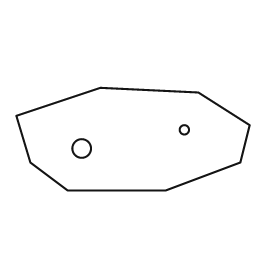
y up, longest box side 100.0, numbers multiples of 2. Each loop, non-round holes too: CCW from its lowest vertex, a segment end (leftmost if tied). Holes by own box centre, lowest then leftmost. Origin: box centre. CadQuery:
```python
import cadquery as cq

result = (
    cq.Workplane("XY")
    .moveTo(-28.0, -22.0)
    .lineTo(14.0, -22.0)
    .lineTo(46.0, -10.0)
    .lineTo(50.0, 6.0)
    .lineTo(28.0, 20.0)
    .lineTo(-14.0, 22.0)
    .lineTo(-50.0, 10.0)
    .lineTo(-44.0, -10.0)
    .close()
    .moveTo(-22.0, -4.0)
    .circle(4.0)
    .moveTo(22.0, 4.0)
    .circle(2.0)
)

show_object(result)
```